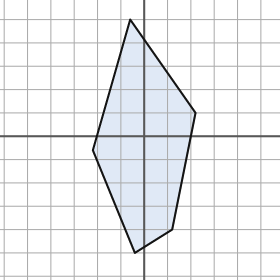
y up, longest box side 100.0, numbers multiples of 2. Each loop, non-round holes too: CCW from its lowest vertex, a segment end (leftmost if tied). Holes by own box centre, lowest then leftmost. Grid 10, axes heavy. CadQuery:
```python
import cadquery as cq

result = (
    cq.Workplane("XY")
    .moveTo(-4.0, -50.0)
    .lineTo(12.0, -40.0)
    .lineTo(22.0, 10.0)
    .lineTo(-6.0, 50.0)
    .lineTo(-22.0, -6.0)
    .close()
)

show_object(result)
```